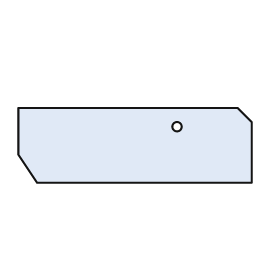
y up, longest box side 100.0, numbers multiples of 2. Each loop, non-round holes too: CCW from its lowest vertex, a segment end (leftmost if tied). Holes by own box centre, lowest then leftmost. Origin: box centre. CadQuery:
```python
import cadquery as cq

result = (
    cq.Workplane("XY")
    .moveTo(-42.0, -16.0)
    .lineTo(50.0, -16.0)
    .lineTo(50.0, 10.0)
    .lineTo(44.0, 16.0)
    .lineTo(-50.0, 16.0)
    .lineTo(-50.0, -4.0)
    .close()
    .moveTo(18.0, 8.0)
    .circle(2.0)
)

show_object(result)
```